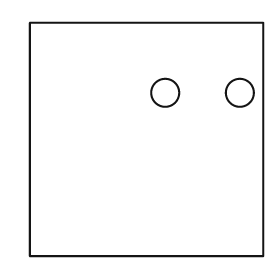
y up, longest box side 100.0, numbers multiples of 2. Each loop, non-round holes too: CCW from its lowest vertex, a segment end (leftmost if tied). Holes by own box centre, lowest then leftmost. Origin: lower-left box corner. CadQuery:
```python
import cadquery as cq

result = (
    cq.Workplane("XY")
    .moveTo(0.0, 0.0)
    .lineTo(100.0, 0.0)
    .lineTo(100.0, 100.0)
    .lineTo(0.0, 100.0)
    .close()
    .moveTo(58.0, 70.0)
    .circle(6.0)
    .moveTo(90.0, 70.0)
    .circle(6.0)
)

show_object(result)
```